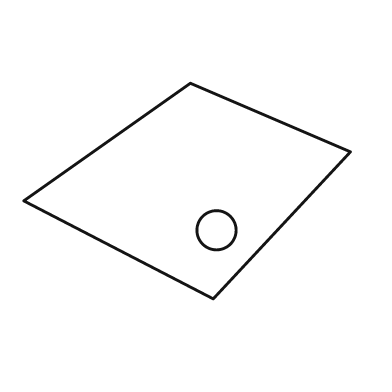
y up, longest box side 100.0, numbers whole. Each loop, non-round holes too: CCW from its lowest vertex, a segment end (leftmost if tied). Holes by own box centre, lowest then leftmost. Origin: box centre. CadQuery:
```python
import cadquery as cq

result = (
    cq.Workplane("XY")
    .moveTo(8.0, -33.0)
    .lineTo(50.0, 12.0)
    .lineTo(1.0, 33.0)
    .lineTo(-50.0, -3.0)
    .close()
    .moveTo(9.0, -12.0)
    .circle(6.0)
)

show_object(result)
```